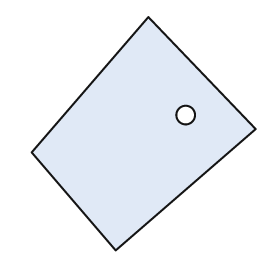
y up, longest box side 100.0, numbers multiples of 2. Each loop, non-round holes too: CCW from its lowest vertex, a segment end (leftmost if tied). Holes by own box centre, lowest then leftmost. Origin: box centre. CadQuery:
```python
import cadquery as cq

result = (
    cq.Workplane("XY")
    .moveTo(-12.0, -50.0)
    .lineTo(48.0, 2.0)
    .lineTo(2.0, 50.0)
    .lineTo(-48.0, -8.0)
    .close()
    .moveTo(18.0, 8.0)
    .circle(4.0)
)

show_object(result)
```